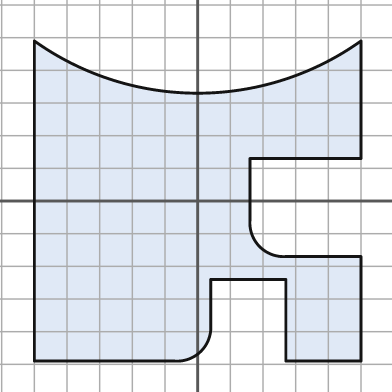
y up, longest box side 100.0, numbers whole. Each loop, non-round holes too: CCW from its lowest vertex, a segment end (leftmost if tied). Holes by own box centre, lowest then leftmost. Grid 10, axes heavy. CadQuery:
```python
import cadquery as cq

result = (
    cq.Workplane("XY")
    .moveTo(-50.0, -49.0)
    .lineTo(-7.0, -49.0)
    .threePointArc((1.0, -46.0), (4.0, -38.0))
    .lineTo(4.0, -24.0)
    .lineTo(27.0, -24.0)
    .lineTo(27.0, -49.0)
    .lineTo(50.0, -49.0)
    .lineTo(50.0, -17.0)
    .lineTo(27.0, -17.0)
    .threePointArc((19.0, -14.0), (16.0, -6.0))
    .lineTo(16.0, 13.0)
    .lineTo(50.0, 13.0)
    .lineTo(50.0, 49.0)
    .threePointArc((0.0, 33.0), (-50.0, 49.0))
    .close()
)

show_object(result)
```